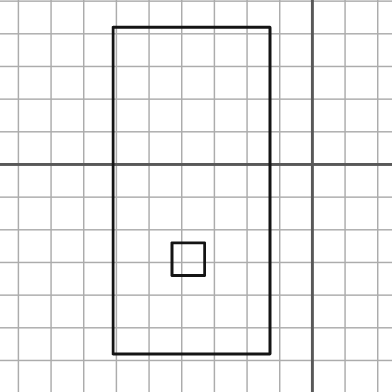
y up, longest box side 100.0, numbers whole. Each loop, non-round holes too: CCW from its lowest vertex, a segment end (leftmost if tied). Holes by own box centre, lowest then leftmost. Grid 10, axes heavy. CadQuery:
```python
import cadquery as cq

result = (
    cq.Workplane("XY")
    .moveTo(-61.0, -58.0)
    .lineTo(-13.0, -58.0)
    .lineTo(-13.0, 42.0)
    .lineTo(-61.0, 42.0)
    .close()
    .moveTo(-43.0, -34.0)
    .lineTo(-33.0, -34.0)
    .lineTo(-33.0, -24.0)
    .lineTo(-43.0, -24.0)
    .close()
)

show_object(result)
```